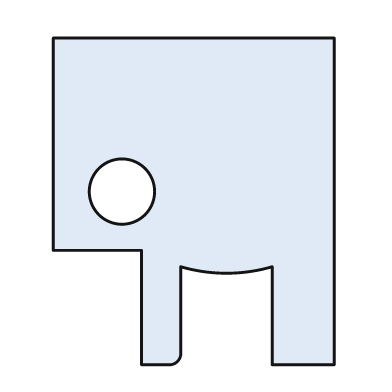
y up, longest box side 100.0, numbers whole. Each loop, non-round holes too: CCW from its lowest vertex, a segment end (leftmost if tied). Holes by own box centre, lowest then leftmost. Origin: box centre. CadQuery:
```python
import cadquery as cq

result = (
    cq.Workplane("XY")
    .moveTo(-16.0, -50.0)
    .lineTo(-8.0, -50.0)
    .threePointArc((-5.0, -49.0), (-4.0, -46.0))
    .lineTo(-4.0, -20.0)
    .threePointArc((10.0, -22.0), (24.0, -20.0))
    .lineTo(24.0, -50.0)
    .lineTo(43.0, -50.0)
    .lineTo(43.0, 50.0)
    .lineTo(-43.0, 50.0)
    .lineTo(-43.0, -15.0)
    .lineTo(-16.0, -15.0)
    .close()
    .moveTo(-22.0, 3.0)
    .circle(10.0)
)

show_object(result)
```